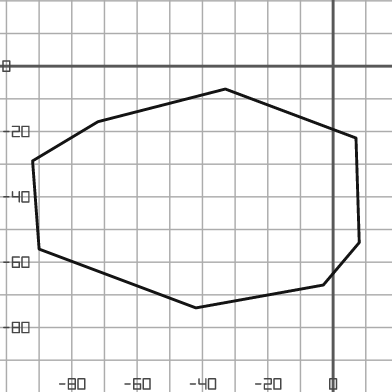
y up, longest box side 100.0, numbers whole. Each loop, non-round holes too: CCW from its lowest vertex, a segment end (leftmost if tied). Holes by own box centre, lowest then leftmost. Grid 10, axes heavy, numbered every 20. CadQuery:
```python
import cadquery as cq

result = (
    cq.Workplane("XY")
    .moveTo(-42.0, -74.0)
    .lineTo(-3.0, -67.0)
    .lineTo(8.0, -54.0)
    .lineTo(7.0, -22.0)
    .lineTo(-33.0, -7.0)
    .lineTo(-72.0, -17.0)
    .lineTo(-92.0, -29.0)
    .lineTo(-90.0, -56.0)
    .close()
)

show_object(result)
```